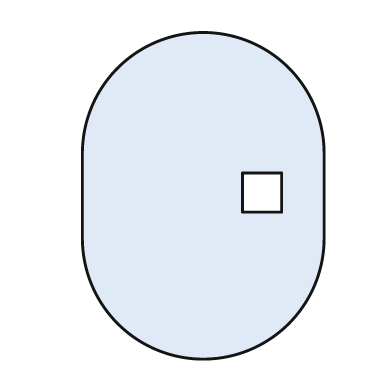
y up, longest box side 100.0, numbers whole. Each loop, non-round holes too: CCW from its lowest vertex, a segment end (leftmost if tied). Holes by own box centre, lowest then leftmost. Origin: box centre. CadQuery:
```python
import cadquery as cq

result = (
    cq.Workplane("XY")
    .moveTo(-37.0, -13.0)
    .threePointArc((0.0, -50.0), (37.0, -13.0))
    .lineTo(37.0, 13.0)
    .threePointArc((0.0, 50.0), (-37.0, 13.0))
    .close()
    .moveTo(12.0, -5.0)
    .lineTo(24.0, -5.0)
    .lineTo(24.0, 7.0)
    .lineTo(12.0, 7.0)
    .close()
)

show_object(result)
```